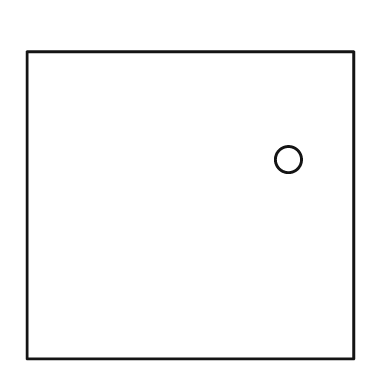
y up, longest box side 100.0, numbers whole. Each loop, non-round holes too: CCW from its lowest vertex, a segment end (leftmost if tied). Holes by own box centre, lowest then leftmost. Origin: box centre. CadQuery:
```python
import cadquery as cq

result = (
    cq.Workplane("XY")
    .moveTo(-50.0, -47.0)
    .lineTo(50.0, -47.0)
    .lineTo(50.0, 47.0)
    .lineTo(-50.0, 47.0)
    .close()
    .moveTo(30.0, 14.0)
    .circle(4.0)
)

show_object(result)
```